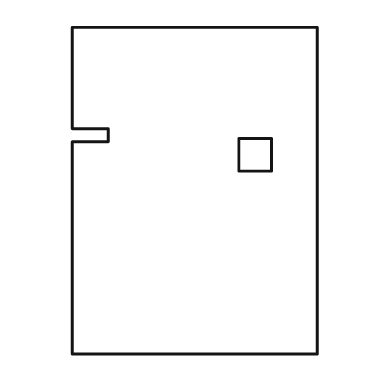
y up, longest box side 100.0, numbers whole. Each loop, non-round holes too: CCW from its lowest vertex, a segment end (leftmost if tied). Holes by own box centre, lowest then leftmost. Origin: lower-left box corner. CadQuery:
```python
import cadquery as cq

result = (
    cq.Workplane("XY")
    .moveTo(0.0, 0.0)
    .lineTo(75.0, 0.0)
    .lineTo(75.0, 100.0)
    .lineTo(0.0, 100.0)
    .lineTo(0.0, 69.0)
    .lineTo(11.0, 69.0)
    .lineTo(11.0, 65.0)
    .lineTo(0.0, 65.0)
    .close()
    .moveTo(51.0, 56.0)
    .lineTo(61.0, 56.0)
    .lineTo(61.0, 66.0)
    .lineTo(51.0, 66.0)
    .close()
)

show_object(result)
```